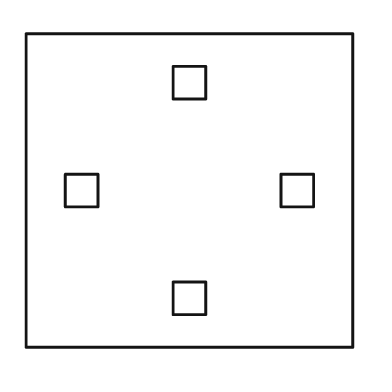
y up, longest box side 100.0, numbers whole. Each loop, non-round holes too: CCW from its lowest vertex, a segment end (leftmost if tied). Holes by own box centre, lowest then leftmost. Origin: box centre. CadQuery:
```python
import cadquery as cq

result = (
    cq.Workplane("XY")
    .moveTo(-50.0, -48.0)
    .lineTo(50.0, -48.0)
    .lineTo(50.0, 48.0)
    .lineTo(-50.0, 48.0)
    .close()
    .moveTo(-5.0, -38.0)
    .lineTo(5.0, -38.0)
    .lineTo(5.0, -28.0)
    .lineTo(-5.0, -28.0)
    .close()
    .moveTo(-38.0, -5.0)
    .lineTo(-28.0, -5.0)
    .lineTo(-28.0, 5.0)
    .lineTo(-38.0, 5.0)
    .close()
    .moveTo(28.0, -5.0)
    .lineTo(38.0, -5.0)
    .lineTo(38.0, 5.0)
    .lineTo(28.0, 5.0)
    .close()
    .moveTo(-5.0, 28.0)
    .lineTo(5.0, 28.0)
    .lineTo(5.0, 38.0)
    .lineTo(-5.0, 38.0)
    .close()
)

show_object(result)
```